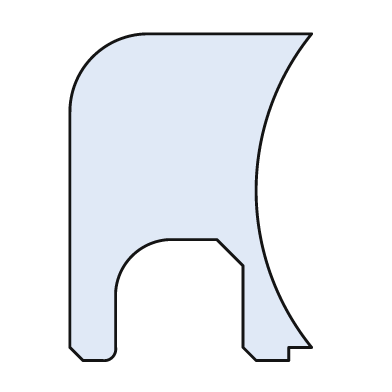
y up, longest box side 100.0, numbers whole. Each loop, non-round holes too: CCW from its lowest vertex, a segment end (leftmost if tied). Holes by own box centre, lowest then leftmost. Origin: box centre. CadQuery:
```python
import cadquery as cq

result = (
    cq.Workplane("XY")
    .moveTo(-33.0, -50.0)
    .lineTo(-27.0, -50.0)
    .threePointArc((-24.0, -49.0), (-23.0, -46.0))
    .lineTo(-23.0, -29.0)
    .threePointArc((-18.0, -18.0), (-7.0, -13.0))
    .lineTo(8.0, -13.0)
    .lineTo(16.0, -21.0)
    .lineTo(16.0, -46.0)
    .lineTo(20.0, -50.0)
    .lineTo(30.0, -50.0)
    .lineTo(30.0, -46.0)
    .lineTo(37.0, -46.0)
    .threePointArc((20.0, 2.0), (37.0, 50.0))
    .lineTo(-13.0, 50.0)
    .threePointArc((-30.0, 43.0), (-37.0, 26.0))
    .lineTo(-37.0, -46.0)
    .close()
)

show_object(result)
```